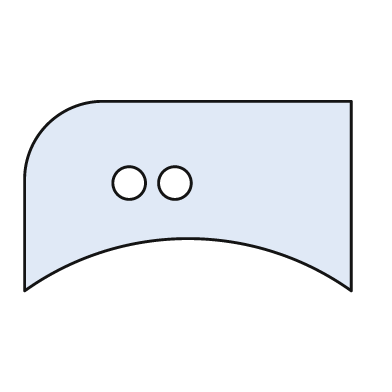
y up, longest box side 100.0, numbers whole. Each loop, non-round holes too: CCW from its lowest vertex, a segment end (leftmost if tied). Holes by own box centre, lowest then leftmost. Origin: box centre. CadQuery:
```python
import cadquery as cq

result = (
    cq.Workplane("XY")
    .moveTo(-50.0, -29.0)
    .threePointArc((0.0, -13.0), (50.0, -29.0))
    .lineTo(50.0, 29.0)
    .lineTo(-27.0, 29.0)
    .threePointArc((-43.0, 22.0), (-50.0, 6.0))
    .close()
    .moveTo(-18.0, 4.0)
    .circle(5.0)
    .moveTo(-4.0, 4.0)
    .circle(5.0)
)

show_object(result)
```